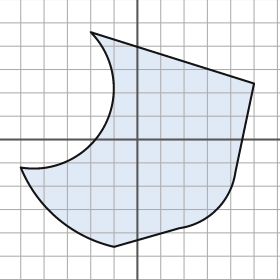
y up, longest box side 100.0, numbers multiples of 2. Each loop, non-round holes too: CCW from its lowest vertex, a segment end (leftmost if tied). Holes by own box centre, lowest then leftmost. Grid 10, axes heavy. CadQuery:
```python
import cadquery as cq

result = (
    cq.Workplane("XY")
    .moveTo(-10.0, -46.0)
    .lineTo(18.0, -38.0)
    .threePointArc((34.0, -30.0), (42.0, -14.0))
    .lineTo(50.0, 24.0)
    .lineTo(-20.0, 46.0)
    .threePointArc((-14.0, 6.0), (-50.0, -12.0))
    .threePointArc((-34.0, -34.0), (-10.0, -46.0))
    .close()
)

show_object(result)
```